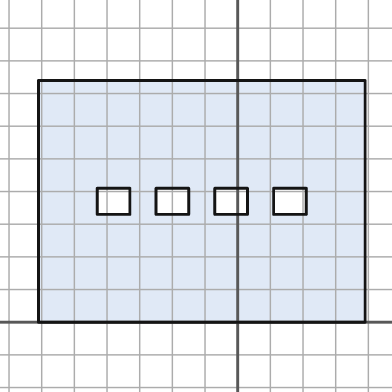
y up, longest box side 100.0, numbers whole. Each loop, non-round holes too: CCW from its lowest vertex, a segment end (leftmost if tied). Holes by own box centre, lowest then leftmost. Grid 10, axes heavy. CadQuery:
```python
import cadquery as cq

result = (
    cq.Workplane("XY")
    .moveTo(-61.0, 0.0)
    .lineTo(39.0, 0.0)
    .lineTo(39.0, 74.0)
    .lineTo(-61.0, 74.0)
    .close()
    .moveTo(-43.0, 33.0)
    .lineTo(-33.0, 33.0)
    .lineTo(-33.0, 41.0)
    .lineTo(-43.0, 41.0)
    .close()
    .moveTo(-25.0, 33.0)
    .lineTo(-15.0, 33.0)
    .lineTo(-15.0, 41.0)
    .lineTo(-25.0, 41.0)
    .close()
    .moveTo(-7.0, 33.0)
    .lineTo(3.0, 33.0)
    .lineTo(3.0, 41.0)
    .lineTo(-7.0, 41.0)
    .close()
    .moveTo(11.0, 33.0)
    .lineTo(21.0, 33.0)
    .lineTo(21.0, 41.0)
    .lineTo(11.0, 41.0)
    .close()
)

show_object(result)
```